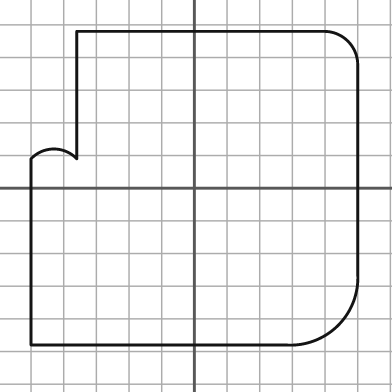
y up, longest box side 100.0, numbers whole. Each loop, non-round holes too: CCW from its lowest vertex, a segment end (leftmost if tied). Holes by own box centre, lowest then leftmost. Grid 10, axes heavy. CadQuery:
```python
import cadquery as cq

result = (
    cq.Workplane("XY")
    .moveTo(-50.0, -48.0)
    .lineTo(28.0, -48.0)
    .threePointArc((44.0, -42.0), (50.0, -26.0))
    .lineTo(50.0, 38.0)
    .threePointArc((47.0, 45.0), (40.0, 48.0))
    .lineTo(-36.0, 48.0)
    .lineTo(-36.0, 9.0)
    .threePointArc((-43.0, 12.0), (-50.0, 9.0))
    .close()
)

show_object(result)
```